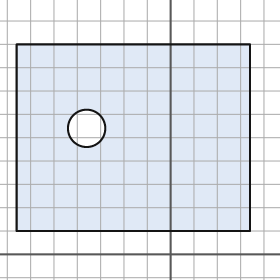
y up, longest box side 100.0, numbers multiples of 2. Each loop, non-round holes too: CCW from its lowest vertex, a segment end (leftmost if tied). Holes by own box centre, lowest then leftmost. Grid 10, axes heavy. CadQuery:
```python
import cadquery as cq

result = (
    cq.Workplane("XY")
    .moveTo(-66.0, 10.0)
    .lineTo(34.0, 10.0)
    .lineTo(34.0, 90.0)
    .lineTo(-66.0, 90.0)
    .close()
    .moveTo(-36.0, 54.0)
    .circle(8.0)
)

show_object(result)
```